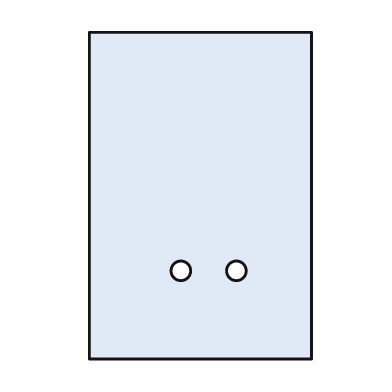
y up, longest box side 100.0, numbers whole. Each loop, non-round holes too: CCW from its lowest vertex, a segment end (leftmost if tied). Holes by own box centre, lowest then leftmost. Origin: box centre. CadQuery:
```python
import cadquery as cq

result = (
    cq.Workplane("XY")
    .moveTo(-34.0, -50.0)
    .lineTo(34.0, -50.0)
    .lineTo(34.0, 50.0)
    .lineTo(-34.0, 50.0)
    .close()
    .moveTo(-6.0, -23.0)
    .circle(3.0)
    .moveTo(11.0, -23.0)
    .circle(3.0)
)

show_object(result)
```